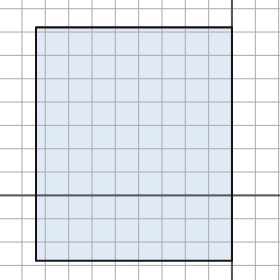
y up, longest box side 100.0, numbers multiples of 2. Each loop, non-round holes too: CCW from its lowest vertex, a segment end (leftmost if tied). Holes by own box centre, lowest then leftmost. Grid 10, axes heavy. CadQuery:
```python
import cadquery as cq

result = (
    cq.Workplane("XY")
    .moveTo(-84.0, -28.0)
    .lineTo(0.0, -28.0)
    .lineTo(0.0, 72.0)
    .lineTo(-84.0, 72.0)
    .close()
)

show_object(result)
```